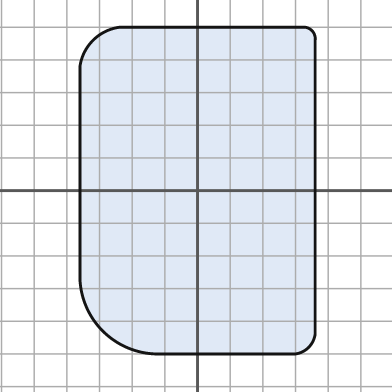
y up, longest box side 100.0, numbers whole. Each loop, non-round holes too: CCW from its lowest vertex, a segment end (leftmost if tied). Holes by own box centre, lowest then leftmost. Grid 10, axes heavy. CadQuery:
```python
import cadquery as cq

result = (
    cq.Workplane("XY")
    .moveTo(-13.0, -50.0)
    .lineTo(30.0, -50.0)
    .threePointArc((34.0, -48.0), (36.0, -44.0))
    .lineTo(36.0, 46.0)
    .threePointArc((35.0, 49.0), (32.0, 50.0))
    .lineTo(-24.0, 50.0)
    .threePointArc((-32.0, 46.0), (-36.0, 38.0))
    .lineTo(-36.0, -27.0)
    .threePointArc((-29.0, -43.0), (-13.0, -50.0))
    .close()
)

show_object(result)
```